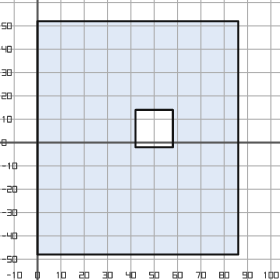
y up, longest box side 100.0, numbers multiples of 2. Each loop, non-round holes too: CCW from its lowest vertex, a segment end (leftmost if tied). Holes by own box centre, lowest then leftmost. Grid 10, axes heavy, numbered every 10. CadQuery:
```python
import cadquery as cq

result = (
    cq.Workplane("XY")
    .moveTo(0.0, -48.0)
    .lineTo(86.0, -48.0)
    .lineTo(86.0, 52.0)
    .lineTo(0.0, 52.0)
    .close()
    .moveTo(42.0, -2.0)
    .lineTo(58.0, -2.0)
    .lineTo(58.0, 14.0)
    .lineTo(42.0, 14.0)
    .close()
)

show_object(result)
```